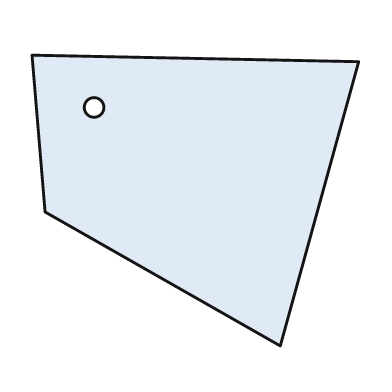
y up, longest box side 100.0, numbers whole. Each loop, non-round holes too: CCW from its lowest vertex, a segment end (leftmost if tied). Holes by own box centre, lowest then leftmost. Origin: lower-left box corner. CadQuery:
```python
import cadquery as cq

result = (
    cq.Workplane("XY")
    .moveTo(76.0, 0.0)
    .lineTo(100.0, 87.0)
    .lineTo(0.0, 89.0)
    .lineTo(4.0, 41.0)
    .close()
    .moveTo(19.0, 73.0)
    .circle(3.0)
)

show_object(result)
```